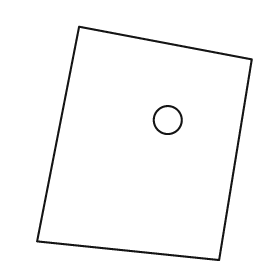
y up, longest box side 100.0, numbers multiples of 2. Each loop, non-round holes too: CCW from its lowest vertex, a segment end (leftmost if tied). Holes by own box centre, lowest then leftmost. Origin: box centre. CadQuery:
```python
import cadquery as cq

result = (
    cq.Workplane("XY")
    .moveTo(32.0, -50.0)
    .lineTo(46.0, 36.0)
    .lineTo(-28.0, 50.0)
    .lineTo(-46.0, -42.0)
    .close()
    .moveTo(10.0, 10.0)
    .circle(6.0)
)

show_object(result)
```